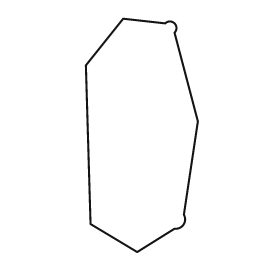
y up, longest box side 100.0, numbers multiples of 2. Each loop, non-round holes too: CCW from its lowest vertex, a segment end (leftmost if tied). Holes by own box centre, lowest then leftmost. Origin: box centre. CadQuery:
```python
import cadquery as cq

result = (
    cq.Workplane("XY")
    .moveTo(-2.0, -50.0)
    .lineTo(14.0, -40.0)
    .threePointArc((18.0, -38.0), (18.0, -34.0))
    .lineTo(24.0, 6.0)
    .lineTo(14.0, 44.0)
    .threePointArc((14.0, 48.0), (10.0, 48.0))
    .lineTo(-8.0, 50.0)
    .lineTo(-24.0, 30.0)
    .lineTo(-22.0, -38.0)
    .close()
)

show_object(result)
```